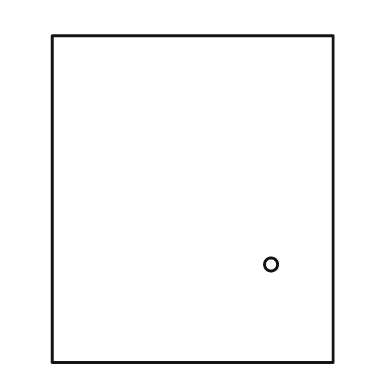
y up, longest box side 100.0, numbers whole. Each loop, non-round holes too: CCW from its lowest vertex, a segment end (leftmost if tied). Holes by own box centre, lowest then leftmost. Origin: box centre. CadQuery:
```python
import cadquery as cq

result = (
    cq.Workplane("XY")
    .moveTo(-43.0, -50.0)
    .lineTo(43.0, -50.0)
    .lineTo(43.0, 50.0)
    .lineTo(-43.0, 50.0)
    .close()
    .moveTo(24.0, -20.0)
    .circle(2.0)
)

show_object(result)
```